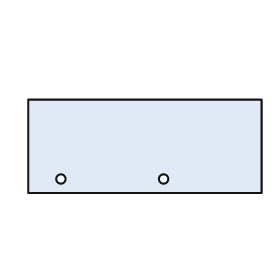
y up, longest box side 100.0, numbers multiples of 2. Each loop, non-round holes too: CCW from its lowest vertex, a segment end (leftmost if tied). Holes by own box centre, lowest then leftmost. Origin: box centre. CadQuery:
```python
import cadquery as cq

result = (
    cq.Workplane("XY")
    .moveTo(-50.0, -20.0)
    .lineTo(50.0, -20.0)
    .lineTo(50.0, 20.0)
    .lineTo(-50.0, 20.0)
    .close()
    .moveTo(-36.0, -14.0)
    .circle(2.0)
    .moveTo(8.0, -14.0)
    .circle(2.0)
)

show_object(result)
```